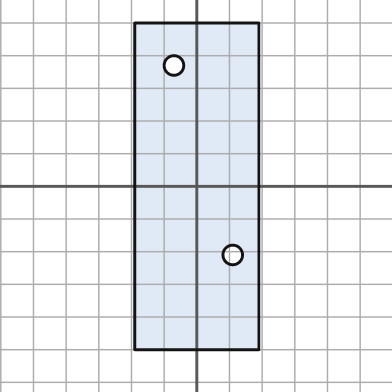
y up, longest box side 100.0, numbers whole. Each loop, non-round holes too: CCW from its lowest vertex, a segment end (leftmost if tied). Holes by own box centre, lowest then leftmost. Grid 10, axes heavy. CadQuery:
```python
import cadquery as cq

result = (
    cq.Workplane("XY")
    .moveTo(-19.0, -50.0)
    .lineTo(19.0, -50.0)
    .lineTo(19.0, 50.0)
    .lineTo(-19.0, 50.0)
    .close()
    .moveTo(11.0, -21.0)
    .circle(3.0)
    .moveTo(-7.0, 37.0)
    .circle(3.0)
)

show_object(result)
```